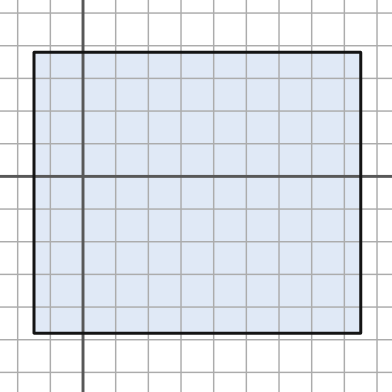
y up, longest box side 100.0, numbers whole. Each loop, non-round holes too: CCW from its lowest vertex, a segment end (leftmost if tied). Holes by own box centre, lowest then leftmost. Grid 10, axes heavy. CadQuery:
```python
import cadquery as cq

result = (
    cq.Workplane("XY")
    .moveTo(-15.0, -48.0)
    .lineTo(85.0, -48.0)
    .lineTo(85.0, 38.0)
    .lineTo(-15.0, 38.0)
    .close()
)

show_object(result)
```